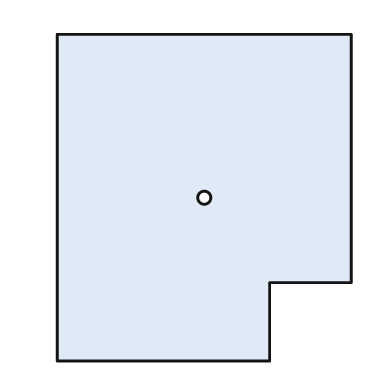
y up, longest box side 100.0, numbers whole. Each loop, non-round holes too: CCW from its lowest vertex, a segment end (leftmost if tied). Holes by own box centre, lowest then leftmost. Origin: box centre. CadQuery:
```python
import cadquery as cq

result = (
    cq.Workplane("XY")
    .moveTo(-45.0, -50.0)
    .lineTo(20.0, -50.0)
    .lineTo(20.0, -26.0)
    .lineTo(45.0, -26.0)
    .lineTo(45.0, 50.0)
    .lineTo(-45.0, 50.0)
    .close()
    .moveTo(0.0, 0.0)
    .circle(2.0)
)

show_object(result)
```